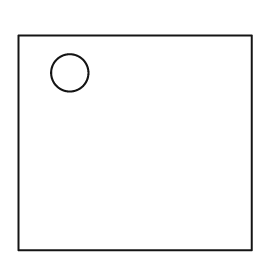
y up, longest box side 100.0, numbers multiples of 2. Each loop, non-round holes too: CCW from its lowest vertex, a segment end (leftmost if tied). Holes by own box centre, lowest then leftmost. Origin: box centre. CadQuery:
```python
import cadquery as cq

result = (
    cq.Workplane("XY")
    .moveTo(-50.0, -46.0)
    .lineTo(50.0, -46.0)
    .lineTo(50.0, 46.0)
    .lineTo(-50.0, 46.0)
    .close()
    .moveTo(-28.0, 30.0)
    .circle(8.0)
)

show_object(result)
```